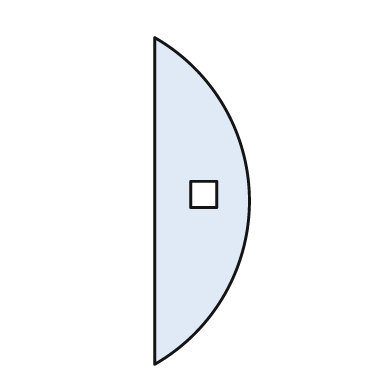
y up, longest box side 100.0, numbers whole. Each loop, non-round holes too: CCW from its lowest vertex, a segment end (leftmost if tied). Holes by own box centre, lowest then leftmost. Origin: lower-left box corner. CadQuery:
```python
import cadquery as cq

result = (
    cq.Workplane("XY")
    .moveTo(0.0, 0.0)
    .threePointArc((29.0, 50.0), (0.0, 100.0))
    .close()
    .moveTo(11.0, 48.0)
    .lineTo(19.0, 48.0)
    .lineTo(19.0, 56.0)
    .lineTo(11.0, 56.0)
    .close()
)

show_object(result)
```